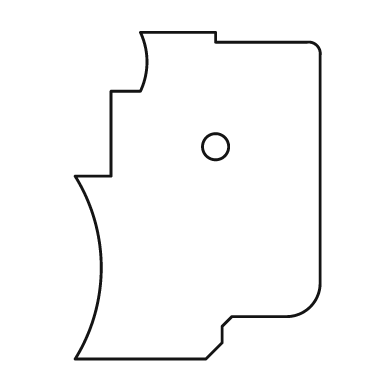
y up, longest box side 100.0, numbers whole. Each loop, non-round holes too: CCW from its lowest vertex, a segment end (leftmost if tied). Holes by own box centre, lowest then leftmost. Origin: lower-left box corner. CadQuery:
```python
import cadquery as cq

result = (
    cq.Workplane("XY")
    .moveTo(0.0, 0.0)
    .lineTo(40.0, 0.0)
    .lineTo(45.0, 5.0)
    .lineTo(45.0, 10.0)
    .lineTo(48.0, 13.0)
    .lineTo(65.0, 13.0)
    .threePointArc((72.0, 16.0), (75.0, 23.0))
    .lineTo(75.0, 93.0)
    .threePointArc((74.0, 96.0), (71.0, 97.0))
    .lineTo(43.0, 97.0)
    .lineTo(43.0, 100.0)
    .lineTo(20.0, 100.0)
    .threePointArc((22.0, 91.0), (20.0, 82.0))
    .lineTo(11.0, 82.0)
    .lineTo(11.0, 56.0)
    .lineTo(0.0, 56.0)
    .threePointArc((8.0, 28.0), (0.0, 0.0))
    .close()
    .moveTo(43.0, 65.0)
    .circle(4.0)
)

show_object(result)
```